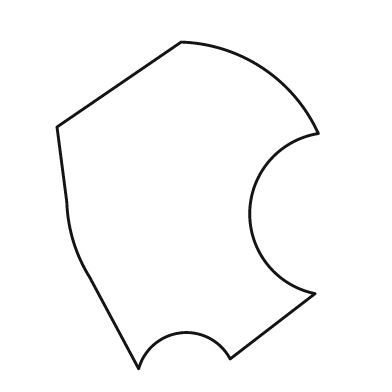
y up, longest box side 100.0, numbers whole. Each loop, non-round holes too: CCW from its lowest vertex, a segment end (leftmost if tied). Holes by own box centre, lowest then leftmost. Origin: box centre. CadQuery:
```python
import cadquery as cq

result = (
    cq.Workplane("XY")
    .moveTo(-15.0, -50.0)
    .threePointArc((-2.0, -39.0), (13.0, -47.0))
    .lineTo(39.0, -27.0)
    .threePointArc((19.0, -2.0), (40.0, 22.0))
    .threePointArc((23.0, 42.0), (-2.0, 50.0))
    .lineTo(-40.0, 24.0)
    .lineTo(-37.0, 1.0)
    .threePointArc((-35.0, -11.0), (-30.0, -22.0))
    .close()
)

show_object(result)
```